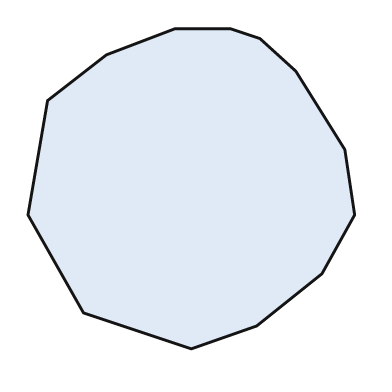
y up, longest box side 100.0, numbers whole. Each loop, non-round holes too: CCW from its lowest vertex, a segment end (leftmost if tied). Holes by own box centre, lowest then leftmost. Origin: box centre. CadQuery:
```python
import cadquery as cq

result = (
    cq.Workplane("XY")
    .moveTo(0.0, -49.0)
    .lineTo(20.0, -42.0)
    .lineTo(40.0, -26.0)
    .lineTo(50.0, -8.0)
    .lineTo(47.0, 12.0)
    .lineTo(32.0, 36.0)
    .lineTo(21.0, 46.0)
    .lineTo(12.0, 49.0)
    .lineTo(-5.0, 49.0)
    .lineTo(-26.0, 41.0)
    .lineTo(-44.0, 27.0)
    .lineTo(-50.0, -8.0)
    .lineTo(-33.0, -38.0)
    .close()
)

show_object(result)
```